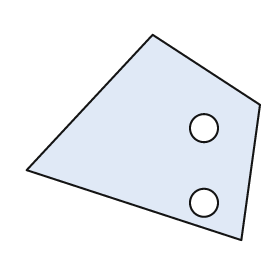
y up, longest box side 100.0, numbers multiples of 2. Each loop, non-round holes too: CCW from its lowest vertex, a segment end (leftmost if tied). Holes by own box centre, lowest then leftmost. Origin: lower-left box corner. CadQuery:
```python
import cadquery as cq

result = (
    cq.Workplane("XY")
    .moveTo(92.0, 0.0)
    .lineTo(100.0, 58.0)
    .lineTo(54.0, 88.0)
    .lineTo(0.0, 30.0)
    .close()
    .moveTo(76.0, 16.0)
    .circle(6.0)
    .moveTo(76.0, 48.0)
    .circle(6.0)
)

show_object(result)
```